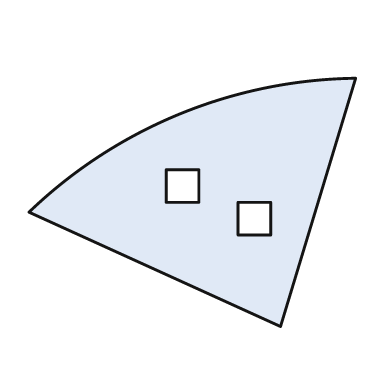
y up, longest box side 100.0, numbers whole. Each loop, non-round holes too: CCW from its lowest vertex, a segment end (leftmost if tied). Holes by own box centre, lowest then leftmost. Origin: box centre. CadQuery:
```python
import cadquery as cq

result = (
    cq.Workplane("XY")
    .moveTo(27.0, -38.0)
    .lineTo(50.0, 38.0)
    .threePointArc((-4.0, 27.0), (-50.0, -3.0))
    .close()
    .moveTo(14.0, -10.0)
    .lineTo(24.0, -10.0)
    .lineTo(24.0, 0.0)
    .lineTo(14.0, 0.0)
    .close()
    .moveTo(-8.0, 0.0)
    .lineTo(2.0, 0.0)
    .lineTo(2.0, 10.0)
    .lineTo(-8.0, 10.0)
    .close()
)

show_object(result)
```